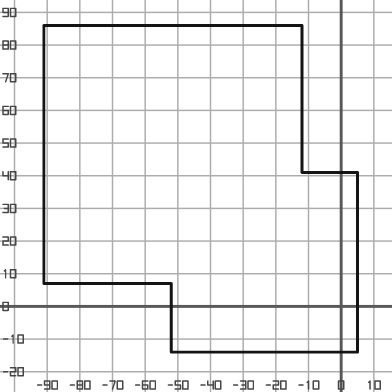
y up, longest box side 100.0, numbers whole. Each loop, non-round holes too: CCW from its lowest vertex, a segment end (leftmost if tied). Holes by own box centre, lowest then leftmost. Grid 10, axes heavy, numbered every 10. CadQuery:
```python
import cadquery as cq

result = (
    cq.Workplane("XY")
    .moveTo(-52.0, -14.0)
    .lineTo(5.0, -14.0)
    .lineTo(5.0, 41.0)
    .lineTo(-12.0, 41.0)
    .lineTo(-12.0, 86.0)
    .lineTo(-91.0, 86.0)
    .lineTo(-91.0, 7.0)
    .lineTo(-52.0, 7.0)
    .close()
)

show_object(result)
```